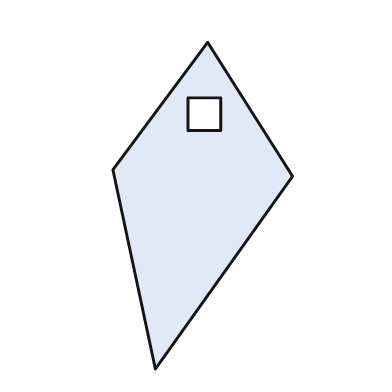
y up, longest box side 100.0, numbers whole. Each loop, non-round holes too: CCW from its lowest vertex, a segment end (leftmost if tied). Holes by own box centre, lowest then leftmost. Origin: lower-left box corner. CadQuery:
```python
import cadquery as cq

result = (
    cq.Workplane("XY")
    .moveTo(13.0, 0.0)
    .lineTo(55.0, 59.0)
    .lineTo(29.0, 100.0)
    .lineTo(0.0, 61.0)
    .close()
    .moveTo(23.0, 73.0)
    .lineTo(33.0, 73.0)
    .lineTo(33.0, 83.0)
    .lineTo(23.0, 83.0)
    .close()
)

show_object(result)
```